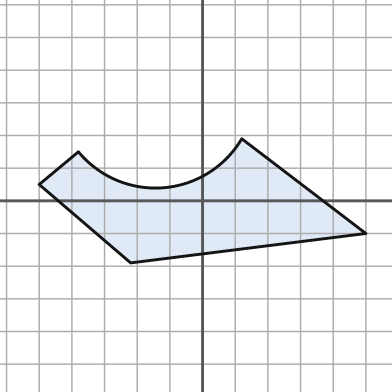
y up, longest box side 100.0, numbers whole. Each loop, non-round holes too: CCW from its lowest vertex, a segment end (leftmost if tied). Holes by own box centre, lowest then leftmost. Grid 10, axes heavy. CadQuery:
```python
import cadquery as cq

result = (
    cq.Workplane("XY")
    .moveTo(-22.0, -19.0)
    .lineTo(50.0, -10.0)
    .lineTo(12.0, 19.0)
    .threePointArc((-12.0, 4.0), (-38.0, 15.0))
    .lineTo(-50.0, 5.0)
    .close()
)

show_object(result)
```